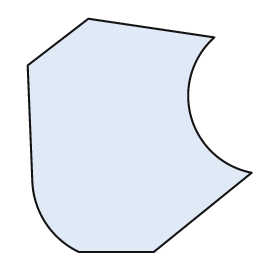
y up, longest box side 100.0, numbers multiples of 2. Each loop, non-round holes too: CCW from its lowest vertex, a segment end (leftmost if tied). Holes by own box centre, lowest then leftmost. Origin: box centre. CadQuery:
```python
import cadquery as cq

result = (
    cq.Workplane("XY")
    .moveTo(-26.0, -50.0)
    .lineTo(6.0, -50.0)
    .lineTo(48.0, -16.0)
    .threePointArc((22.0, 8.0), (32.0, 42.0))
    .lineTo(-22.0, 50.0)
    .lineTo(-48.0, 30.0)
    .lineTo(-46.0, -20.0)
    .threePointArc((-40.0, -38.0), (-26.0, -50.0))
    .close()
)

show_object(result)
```